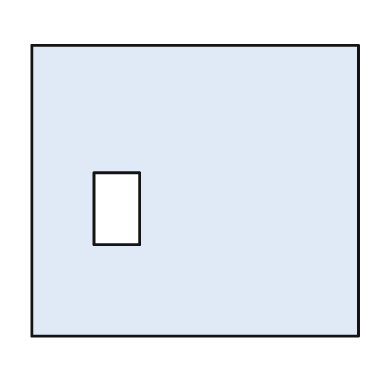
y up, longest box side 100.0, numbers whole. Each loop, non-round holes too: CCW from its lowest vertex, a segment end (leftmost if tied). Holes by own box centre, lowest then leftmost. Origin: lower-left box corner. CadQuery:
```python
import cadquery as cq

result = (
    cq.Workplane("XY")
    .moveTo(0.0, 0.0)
    .lineTo(100.0, 0.0)
    .lineTo(100.0, 89.0)
    .lineTo(0.0, 89.0)
    .close()
    .moveTo(19.0, 28.0)
    .lineTo(33.0, 28.0)
    .lineTo(33.0, 50.0)
    .lineTo(19.0, 50.0)
    .close()
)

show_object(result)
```